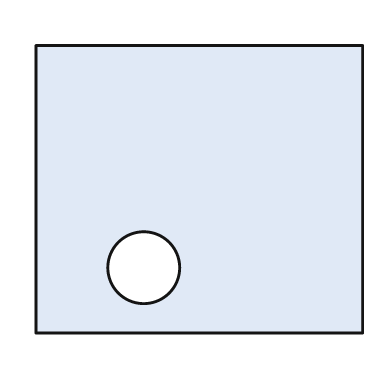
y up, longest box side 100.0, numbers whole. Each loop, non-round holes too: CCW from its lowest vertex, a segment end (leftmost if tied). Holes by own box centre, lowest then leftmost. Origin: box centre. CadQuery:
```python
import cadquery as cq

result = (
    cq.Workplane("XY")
    .moveTo(-50.0, -44.0)
    .lineTo(50.0, -44.0)
    .lineTo(50.0, 44.0)
    .lineTo(-50.0, 44.0)
    .close()
    .moveTo(-17.0, -24.0)
    .circle(11.0)
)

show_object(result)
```